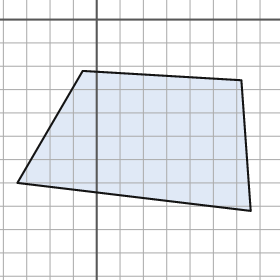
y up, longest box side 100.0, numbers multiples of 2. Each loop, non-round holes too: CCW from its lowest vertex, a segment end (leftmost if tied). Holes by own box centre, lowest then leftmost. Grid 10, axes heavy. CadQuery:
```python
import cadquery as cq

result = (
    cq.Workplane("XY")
    .moveTo(66.0, -82.0)
    .lineTo(62.0, -26.0)
    .lineTo(-6.0, -22.0)
    .lineTo(-34.0, -70.0)
    .close()
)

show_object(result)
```